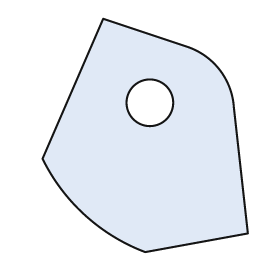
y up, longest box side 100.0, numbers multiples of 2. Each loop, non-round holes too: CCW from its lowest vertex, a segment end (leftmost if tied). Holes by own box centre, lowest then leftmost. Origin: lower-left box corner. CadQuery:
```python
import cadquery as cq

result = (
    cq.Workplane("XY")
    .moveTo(44.0, 0.0)
    .lineTo(88.0, 8.0)
    .lineTo(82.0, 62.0)
    .threePointArc((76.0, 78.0), (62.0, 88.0))
    .lineTo(26.0, 100.0)
    .lineTo(0.0, 40.0)
    .threePointArc((18.0, 16.0), (44.0, 0.0))
    .close()
    .moveTo(46.0, 64.0)
    .circle(10.0)
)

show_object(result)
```